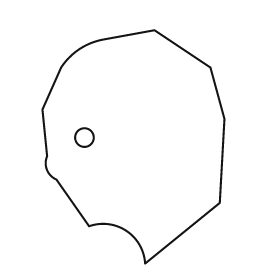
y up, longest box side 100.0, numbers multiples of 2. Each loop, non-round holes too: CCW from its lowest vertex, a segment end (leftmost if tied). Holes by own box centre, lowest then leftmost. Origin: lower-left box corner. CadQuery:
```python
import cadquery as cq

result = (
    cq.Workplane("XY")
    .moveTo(44.0, 0.0)
    .lineTo(76.0, 26.0)
    .lineTo(78.0, 62.0)
    .lineTo(72.0, 84.0)
    .lineTo(48.0, 100.0)
    .lineTo(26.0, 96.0)
    .threePointArc((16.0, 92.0), (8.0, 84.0))
    .lineTo(0.0, 66.0)
    .lineTo(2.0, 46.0)
    .threePointArc((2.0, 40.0), (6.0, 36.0))
    .lineTo(20.0, 16.0)
    .threePointArc((36.0, 14.0), (44.0, 0.0))
    .close()
    .moveTo(18.0, 54.0)
    .circle(4.0)
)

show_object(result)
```